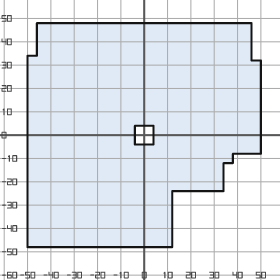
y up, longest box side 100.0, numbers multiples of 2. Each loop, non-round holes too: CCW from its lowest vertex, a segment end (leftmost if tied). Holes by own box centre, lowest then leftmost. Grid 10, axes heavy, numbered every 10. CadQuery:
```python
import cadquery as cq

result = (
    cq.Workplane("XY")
    .moveTo(-50.0, -48.0)
    .lineTo(12.0, -48.0)
    .lineTo(12.0, -24.0)
    .lineTo(34.0, -24.0)
    .lineTo(34.0, -12.0)
    .lineTo(38.0, -12.0)
    .lineTo(38.0, -8.0)
    .lineTo(50.0, -8.0)
    .lineTo(50.0, 32.0)
    .lineTo(46.0, 32.0)
    .lineTo(46.0, 48.0)
    .lineTo(-46.0, 48.0)
    .lineTo(-46.0, 34.0)
    .lineTo(-50.0, 34.0)
    .close()
    .moveTo(-4.0, -4.0)
    .lineTo(4.0, -4.0)
    .lineTo(4.0, 4.0)
    .lineTo(-4.0, 4.0)
    .close()
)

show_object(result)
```